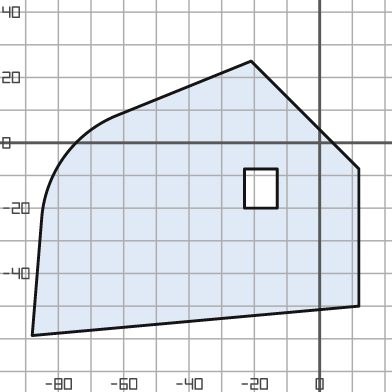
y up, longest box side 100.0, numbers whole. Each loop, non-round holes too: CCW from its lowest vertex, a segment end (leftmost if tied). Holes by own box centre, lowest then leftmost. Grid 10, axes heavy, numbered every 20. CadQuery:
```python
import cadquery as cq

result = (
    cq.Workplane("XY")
    .moveTo(-88.0, -59.0)
    .lineTo(12.0, -50.0)
    .lineTo(12.0, -8.0)
    .lineTo(-21.0, 25.0)
    .lineTo(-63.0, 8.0)
    .threePointArc((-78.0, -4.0), (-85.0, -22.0))
    .close()
    .moveTo(-23.0, -20.0)
    .lineTo(-13.0, -20.0)
    .lineTo(-13.0, -8.0)
    .lineTo(-23.0, -8.0)
    .close()
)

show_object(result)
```